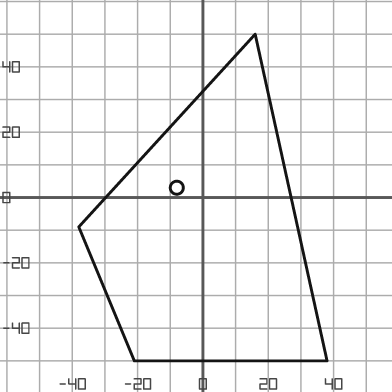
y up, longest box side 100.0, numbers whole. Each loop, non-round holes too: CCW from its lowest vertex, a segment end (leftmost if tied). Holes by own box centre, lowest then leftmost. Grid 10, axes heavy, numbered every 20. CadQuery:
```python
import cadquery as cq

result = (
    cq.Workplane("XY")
    .moveTo(-21.0, -50.0)
    .lineTo(38.0, -50.0)
    .lineTo(16.0, 50.0)
    .lineTo(-38.0, -9.0)
    .close()
    .moveTo(-8.0, 3.0)
    .circle(2.0)
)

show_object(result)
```